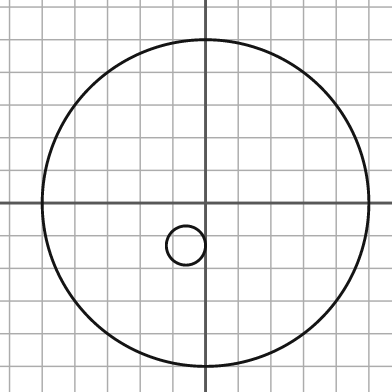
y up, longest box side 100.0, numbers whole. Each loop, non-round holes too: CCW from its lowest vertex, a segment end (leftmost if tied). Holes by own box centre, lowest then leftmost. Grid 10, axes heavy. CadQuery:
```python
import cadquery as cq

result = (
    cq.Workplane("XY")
    .moveTo(0.0, 0.0)
    .circle(50.0)
    .moveTo(-6.0, -13.0)
    .circle(6.0)
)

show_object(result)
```